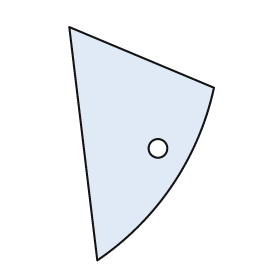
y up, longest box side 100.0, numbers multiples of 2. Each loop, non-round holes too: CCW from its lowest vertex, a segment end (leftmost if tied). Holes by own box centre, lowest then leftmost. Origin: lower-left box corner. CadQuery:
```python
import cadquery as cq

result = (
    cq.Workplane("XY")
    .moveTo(12.0, 0.0)
    .threePointArc((44.0, 32.0), (62.0, 74.0))
    .lineTo(0.0, 100.0)
    .close()
    .moveTo(38.0, 48.0)
    .circle(4.0)
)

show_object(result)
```